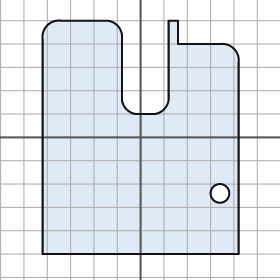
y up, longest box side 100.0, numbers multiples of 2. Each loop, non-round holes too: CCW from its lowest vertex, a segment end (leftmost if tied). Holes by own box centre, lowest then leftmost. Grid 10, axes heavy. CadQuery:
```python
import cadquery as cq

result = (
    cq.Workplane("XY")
    .moveTo(-42.0, -50.0)
    .lineTo(42.0, -50.0)
    .lineTo(42.0, 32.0)
    .threePointArc((40.0, 38.0), (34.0, 40.0))
    .lineTo(16.0, 40.0)
    .lineTo(16.0, 50.0)
    .lineTo(12.0, 50.0)
    .lineTo(12.0, 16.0)
    .threePointArc((10.0, 12.0), (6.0, 10.0))
    .lineTo(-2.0, 10.0)
    .threePointArc((-6.0, 12.0), (-8.0, 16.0))
    .lineTo(-8.0, 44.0)
    .threePointArc((-10.0, 48.0), (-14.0, 50.0))
    .lineTo(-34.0, 50.0)
    .threePointArc((-40.0, 48.0), (-42.0, 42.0))
    .close()
    .moveTo(34.0, -24.0)
    .circle(4.0)
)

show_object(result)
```